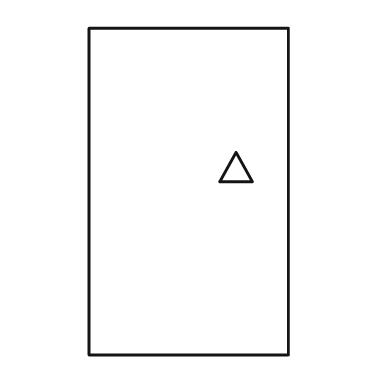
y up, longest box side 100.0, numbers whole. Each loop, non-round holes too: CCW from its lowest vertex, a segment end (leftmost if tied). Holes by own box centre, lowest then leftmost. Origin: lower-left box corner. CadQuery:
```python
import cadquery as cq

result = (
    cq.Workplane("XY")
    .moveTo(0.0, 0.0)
    .lineTo(61.0, 0.0)
    .lineTo(61.0, 100.0)
    .lineTo(0.0, 100.0)
    .close()
    .moveTo(40.0, 53.0)
    .lineTo(50.0, 53.0)
    .lineTo(45.0, 62.0)
    .close()
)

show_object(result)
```